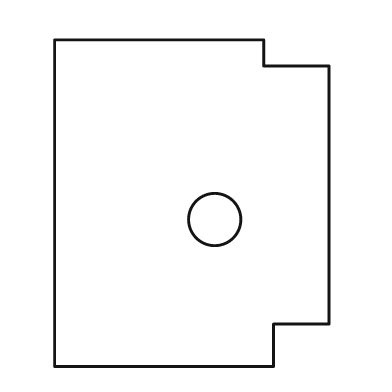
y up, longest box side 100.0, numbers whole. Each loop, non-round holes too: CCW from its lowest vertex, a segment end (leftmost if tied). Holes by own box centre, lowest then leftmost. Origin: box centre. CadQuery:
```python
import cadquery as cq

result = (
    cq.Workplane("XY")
    .moveTo(-42.0, -50.0)
    .lineTo(25.0, -50.0)
    .lineTo(25.0, -37.0)
    .lineTo(42.0, -37.0)
    .lineTo(42.0, 42.0)
    .lineTo(22.0, 42.0)
    .lineTo(22.0, 50.0)
    .lineTo(-42.0, 50.0)
    .close()
    .moveTo(7.0, -5.0)
    .circle(8.0)
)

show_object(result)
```